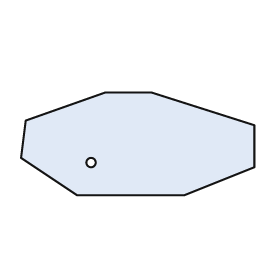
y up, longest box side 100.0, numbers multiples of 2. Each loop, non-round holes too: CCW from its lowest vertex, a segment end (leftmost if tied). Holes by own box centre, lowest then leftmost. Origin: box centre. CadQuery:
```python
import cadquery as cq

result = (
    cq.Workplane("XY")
    .moveTo(-26.0, -22.0)
    .lineTo(20.0, -22.0)
    .lineTo(50.0, -10.0)
    .lineTo(50.0, 8.0)
    .lineTo(6.0, 22.0)
    .lineTo(-14.0, 22.0)
    .lineTo(-48.0, 10.0)
    .lineTo(-50.0, -6.0)
    .close()
    .moveTo(-20.0, -8.0)
    .circle(2.0)
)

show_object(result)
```